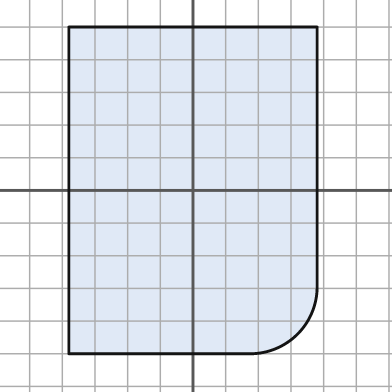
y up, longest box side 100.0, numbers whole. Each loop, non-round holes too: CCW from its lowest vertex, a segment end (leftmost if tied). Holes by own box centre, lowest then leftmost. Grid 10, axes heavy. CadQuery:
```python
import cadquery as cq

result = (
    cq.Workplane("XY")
    .moveTo(-38.0, -50.0)
    .lineTo(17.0, -50.0)
    .threePointArc((32.0, -44.0), (38.0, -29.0))
    .lineTo(38.0, 50.0)
    .lineTo(-38.0, 50.0)
    .close()
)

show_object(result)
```